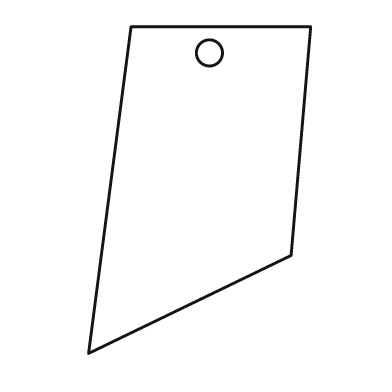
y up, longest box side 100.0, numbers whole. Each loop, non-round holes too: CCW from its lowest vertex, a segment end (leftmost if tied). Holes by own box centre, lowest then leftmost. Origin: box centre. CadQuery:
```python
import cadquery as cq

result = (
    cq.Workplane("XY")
    .moveTo(-34.0, -50.0)
    .lineTo(28.0, -20.0)
    .lineTo(34.0, 50.0)
    .lineTo(-21.0, 50.0)
    .close()
    .moveTo(3.0, 42.0)
    .circle(4.0)
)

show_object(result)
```